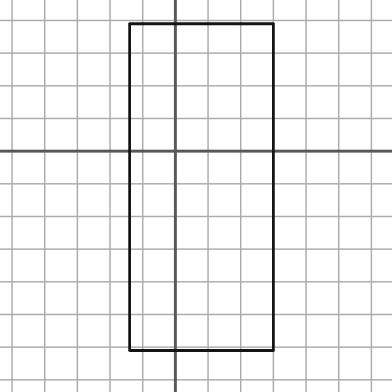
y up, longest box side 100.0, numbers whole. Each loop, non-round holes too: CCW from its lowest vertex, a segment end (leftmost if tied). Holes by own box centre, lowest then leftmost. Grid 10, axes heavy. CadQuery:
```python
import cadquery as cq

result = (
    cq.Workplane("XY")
    .moveTo(-14.0, -61.0)
    .lineTo(30.0, -61.0)
    .lineTo(30.0, 39.0)
    .lineTo(-14.0, 39.0)
    .close()
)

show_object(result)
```